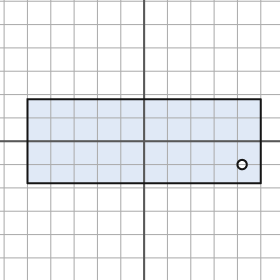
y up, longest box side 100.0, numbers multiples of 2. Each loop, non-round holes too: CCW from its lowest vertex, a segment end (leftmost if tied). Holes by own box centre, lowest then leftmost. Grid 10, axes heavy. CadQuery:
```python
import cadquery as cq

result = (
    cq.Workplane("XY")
    .moveTo(-50.0, -18.0)
    .lineTo(50.0, -18.0)
    .lineTo(50.0, 18.0)
    .lineTo(-50.0, 18.0)
    .close()
    .moveTo(42.0, -10.0)
    .circle(2.0)
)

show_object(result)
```